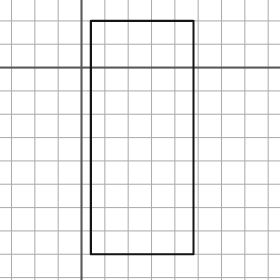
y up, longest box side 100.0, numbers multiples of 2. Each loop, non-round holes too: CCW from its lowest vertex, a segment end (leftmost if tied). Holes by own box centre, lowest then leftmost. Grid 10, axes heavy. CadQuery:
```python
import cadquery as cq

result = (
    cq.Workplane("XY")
    .moveTo(4.0, -80.0)
    .lineTo(48.0, -80.0)
    .lineTo(48.0, 20.0)
    .lineTo(4.0, 20.0)
    .close()
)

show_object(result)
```